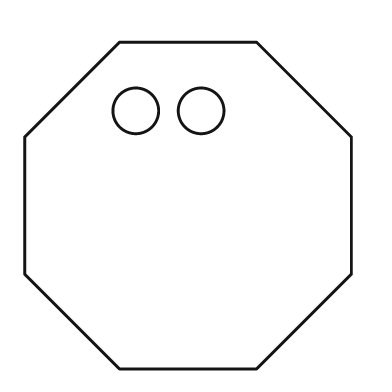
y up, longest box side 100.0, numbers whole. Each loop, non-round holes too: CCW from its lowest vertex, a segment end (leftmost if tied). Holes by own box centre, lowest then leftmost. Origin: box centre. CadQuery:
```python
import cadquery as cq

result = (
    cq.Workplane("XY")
    .moveTo(-21.0, -50.0)
    .lineTo(21.0, -50.0)
    .lineTo(50.0, -21.0)
    .lineTo(50.0, 21.0)
    .lineTo(21.0, 50.0)
    .lineTo(-21.0, 50.0)
    .lineTo(-50.0, 21.0)
    .lineTo(-50.0, -21.0)
    .close()
    .moveTo(-16.0, 29.0)
    .circle(7.0)
    .moveTo(4.0, 29.0)
    .circle(7.0)
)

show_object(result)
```